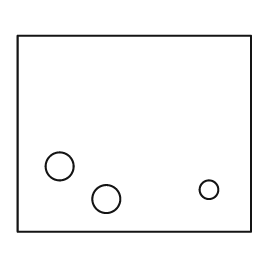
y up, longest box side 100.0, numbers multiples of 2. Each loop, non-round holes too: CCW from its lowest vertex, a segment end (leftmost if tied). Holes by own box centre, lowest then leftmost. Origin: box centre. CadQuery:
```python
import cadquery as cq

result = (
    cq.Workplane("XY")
    .moveTo(-50.0, -42.0)
    .lineTo(50.0, -42.0)
    .lineTo(50.0, 42.0)
    .lineTo(-50.0, 42.0)
    .close()
    .moveTo(-12.0, -28.0)
    .circle(6.0)
    .moveTo(32.0, -24.0)
    .circle(4.0)
    .moveTo(-32.0, -14.0)
    .circle(6.0)
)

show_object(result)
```